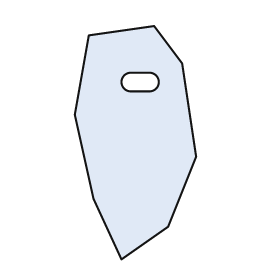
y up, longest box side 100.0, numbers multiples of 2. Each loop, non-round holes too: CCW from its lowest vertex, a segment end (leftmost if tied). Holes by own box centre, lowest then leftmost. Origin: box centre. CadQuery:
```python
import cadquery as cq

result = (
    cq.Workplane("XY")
    .moveTo(-6.0, -50.0)
    .lineTo(14.0, -36.0)
    .lineTo(26.0, -6.0)
    .lineTo(20.0, 34.0)
    .lineTo(8.0, 50.0)
    .lineTo(-20.0, 46.0)
    .lineTo(-26.0, 12.0)
    .lineTo(-18.0, -24.0)
    .close()
    .moveTo(-2.0, 22.0)
    .lineTo(6.0, 22.0)
    .threePointArc((10.0, 26.0), (6.0, 30.0))
    .lineTo(-2.0, 30.0)
    .threePointArc((-6.0, 26.0), (-2.0, 22.0))
    .close()
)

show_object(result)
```